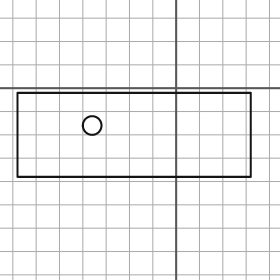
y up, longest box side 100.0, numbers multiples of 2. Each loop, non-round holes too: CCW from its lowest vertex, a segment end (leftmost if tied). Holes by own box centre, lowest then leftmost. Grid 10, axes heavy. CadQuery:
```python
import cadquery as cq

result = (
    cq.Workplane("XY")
    .moveTo(-68.0, -38.0)
    .lineTo(32.0, -38.0)
    .lineTo(32.0, -2.0)
    .lineTo(-68.0, -2.0)
    .close()
    .moveTo(-36.0, -16.0)
    .circle(4.0)
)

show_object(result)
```